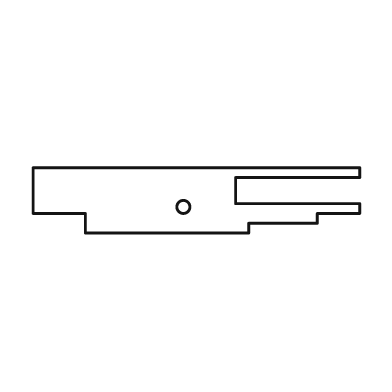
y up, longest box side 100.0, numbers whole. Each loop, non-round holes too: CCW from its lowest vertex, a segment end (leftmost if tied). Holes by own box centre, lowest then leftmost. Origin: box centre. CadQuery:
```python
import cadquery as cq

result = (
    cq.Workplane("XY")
    .moveTo(-34.0, -10.0)
    .lineTo(16.0, -10.0)
    .lineTo(16.0, -7.0)
    .lineTo(37.0, -7.0)
    .lineTo(37.0, -4.0)
    .lineTo(50.0, -4.0)
    .lineTo(50.0, -1.0)
    .lineTo(12.0, -1.0)
    .lineTo(12.0, 7.0)
    .lineTo(50.0, 7.0)
    .lineTo(50.0, 10.0)
    .lineTo(-50.0, 10.0)
    .lineTo(-50.0, -4.0)
    .lineTo(-34.0, -4.0)
    .close()
    .moveTo(-4.0, -2.0)
    .circle(2.0)
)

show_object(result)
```